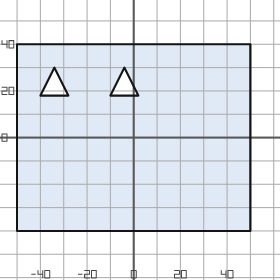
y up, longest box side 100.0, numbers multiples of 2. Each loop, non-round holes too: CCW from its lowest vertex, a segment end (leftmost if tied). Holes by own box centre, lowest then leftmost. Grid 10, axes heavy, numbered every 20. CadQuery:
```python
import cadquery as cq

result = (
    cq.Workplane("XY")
    .moveTo(-50.0, -40.0)
    .lineTo(50.0, -40.0)
    .lineTo(50.0, 40.0)
    .lineTo(-50.0, 40.0)
    .close()
    .moveTo(-40.0, 18.0)
    .lineTo(-28.0, 18.0)
    .lineTo(-34.0, 30.0)
    .close()
    .moveTo(-10.0, 18.0)
    .lineTo(2.0, 18.0)
    .lineTo(-4.0, 30.0)
    .close()
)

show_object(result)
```